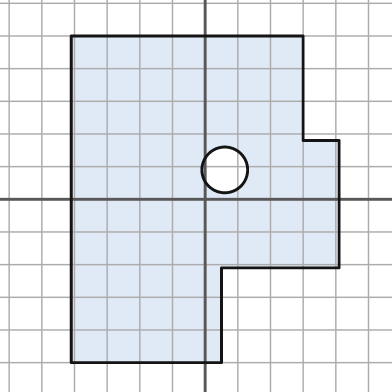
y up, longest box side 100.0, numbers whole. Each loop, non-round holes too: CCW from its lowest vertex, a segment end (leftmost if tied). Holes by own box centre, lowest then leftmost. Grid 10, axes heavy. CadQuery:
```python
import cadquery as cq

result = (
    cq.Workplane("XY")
    .moveTo(-41.0, -50.0)
    .lineTo(5.0, -50.0)
    .lineTo(5.0, -21.0)
    .lineTo(41.0, -21.0)
    .lineTo(41.0, 18.0)
    .lineTo(30.0, 18.0)
    .lineTo(30.0, 50.0)
    .lineTo(-41.0, 50.0)
    .close()
    .moveTo(6.0, 9.0)
    .circle(7.0)
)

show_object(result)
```